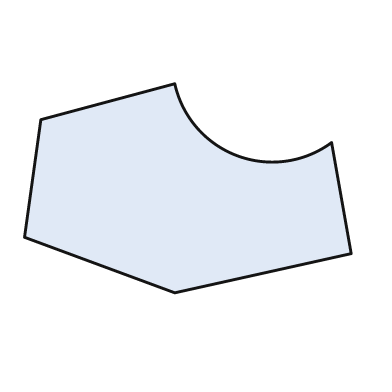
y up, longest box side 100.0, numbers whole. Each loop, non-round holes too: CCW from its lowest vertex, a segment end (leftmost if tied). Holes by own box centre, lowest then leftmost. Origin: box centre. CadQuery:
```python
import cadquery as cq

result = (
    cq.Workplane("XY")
    .moveTo(-4.0, -32.0)
    .lineTo(50.0, -20.0)
    .lineTo(44.0, 14.0)
    .threePointArc((15.0, 10.0), (-4.0, 32.0))
    .lineTo(-45.0, 21.0)
    .lineTo(-50.0, -15.0)
    .close()
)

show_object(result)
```